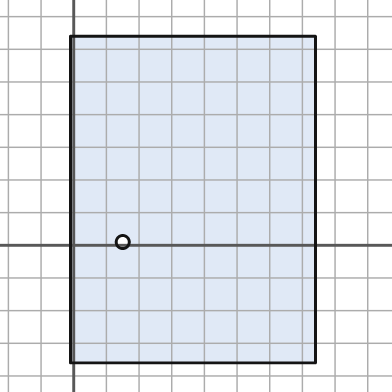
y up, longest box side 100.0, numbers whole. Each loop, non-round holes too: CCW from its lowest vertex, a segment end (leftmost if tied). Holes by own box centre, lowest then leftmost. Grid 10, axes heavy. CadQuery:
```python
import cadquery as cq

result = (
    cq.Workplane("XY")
    .moveTo(-1.0, -36.0)
    .lineTo(74.0, -36.0)
    .lineTo(74.0, 64.0)
    .lineTo(-1.0, 64.0)
    .close()
    .moveTo(15.0, 1.0)
    .circle(2.0)
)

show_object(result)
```